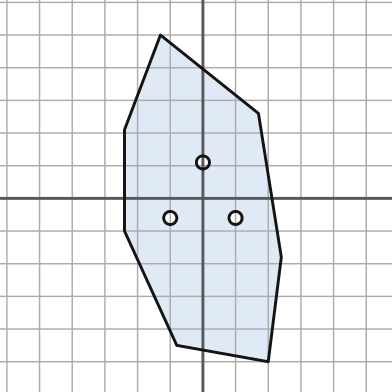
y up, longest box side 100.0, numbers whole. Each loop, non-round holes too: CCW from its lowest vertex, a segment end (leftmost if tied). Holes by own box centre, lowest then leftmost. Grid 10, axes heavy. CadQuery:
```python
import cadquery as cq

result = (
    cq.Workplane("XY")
    .moveTo(20.0, -50.0)
    .lineTo(24.0, -18.0)
    .lineTo(17.0, 26.0)
    .lineTo(-13.0, 50.0)
    .lineTo(-24.0, 21.0)
    .lineTo(-24.0, -10.0)
    .lineTo(-8.0, -45.0)
    .close()
    .moveTo(-10.0, -6.0)
    .circle(2.0)
    .moveTo(10.0, -6.0)
    .circle(2.0)
    .moveTo(0.0, 11.0)
    .circle(2.0)
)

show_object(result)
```